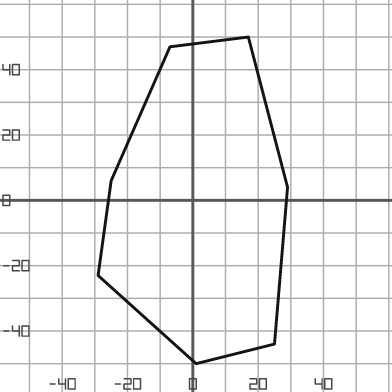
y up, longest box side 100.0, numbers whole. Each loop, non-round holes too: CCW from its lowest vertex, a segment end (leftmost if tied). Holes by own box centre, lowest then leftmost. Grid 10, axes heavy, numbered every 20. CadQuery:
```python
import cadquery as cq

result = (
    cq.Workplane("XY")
    .moveTo(1.0, -50.0)
    .lineTo(25.0, -44.0)
    .lineTo(29.0, 4.0)
    .lineTo(17.0, 50.0)
    .lineTo(-7.0, 47.0)
    .lineTo(-25.0, 6.0)
    .lineTo(-29.0, -23.0)
    .close()
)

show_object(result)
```